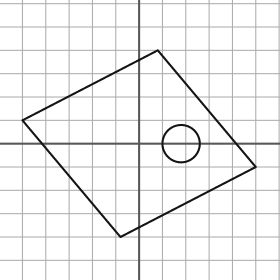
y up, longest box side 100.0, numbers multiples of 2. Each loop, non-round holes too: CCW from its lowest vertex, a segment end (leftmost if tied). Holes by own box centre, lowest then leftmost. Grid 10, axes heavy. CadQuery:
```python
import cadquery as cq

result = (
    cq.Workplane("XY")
    .moveTo(-8.0, -40.0)
    .lineTo(50.0, -10.0)
    .lineTo(8.0, 40.0)
    .lineTo(-50.0, 10.0)
    .close()
    .moveTo(18.0, 0.0)
    .circle(8.0)
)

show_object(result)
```